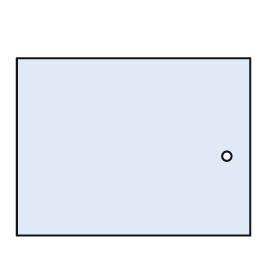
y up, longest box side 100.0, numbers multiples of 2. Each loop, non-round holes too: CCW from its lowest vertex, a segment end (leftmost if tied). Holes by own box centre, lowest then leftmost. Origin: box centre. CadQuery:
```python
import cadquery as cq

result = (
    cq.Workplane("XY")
    .moveTo(-50.0, -38.0)
    .lineTo(50.0, -38.0)
    .lineTo(50.0, 38.0)
    .lineTo(-50.0, 38.0)
    .close()
    .moveTo(40.0, -4.0)
    .circle(2.0)
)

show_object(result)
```